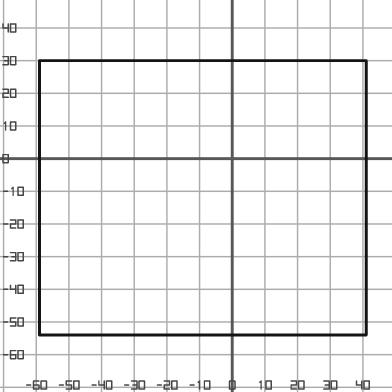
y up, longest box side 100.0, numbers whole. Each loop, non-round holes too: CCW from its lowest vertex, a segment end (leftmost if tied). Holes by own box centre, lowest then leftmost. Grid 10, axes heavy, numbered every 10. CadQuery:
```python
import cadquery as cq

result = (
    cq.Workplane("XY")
    .moveTo(-59.0, -54.0)
    .lineTo(41.0, -54.0)
    .lineTo(41.0, 30.0)
    .lineTo(-59.0, 30.0)
    .close()
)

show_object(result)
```